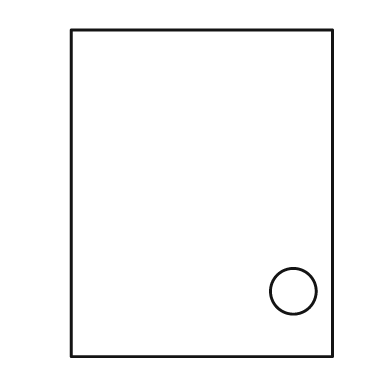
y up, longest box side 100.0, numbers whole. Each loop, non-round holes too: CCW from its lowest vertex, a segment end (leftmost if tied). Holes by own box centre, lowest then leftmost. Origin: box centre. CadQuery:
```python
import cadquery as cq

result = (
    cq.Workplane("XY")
    .moveTo(-40.0, -50.0)
    .lineTo(40.0, -50.0)
    .lineTo(40.0, 50.0)
    .lineTo(-40.0, 50.0)
    .close()
    .moveTo(28.0, -30.0)
    .circle(7.0)
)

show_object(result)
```